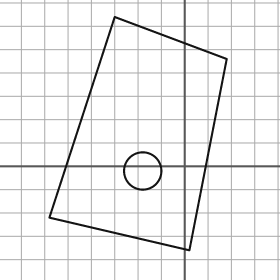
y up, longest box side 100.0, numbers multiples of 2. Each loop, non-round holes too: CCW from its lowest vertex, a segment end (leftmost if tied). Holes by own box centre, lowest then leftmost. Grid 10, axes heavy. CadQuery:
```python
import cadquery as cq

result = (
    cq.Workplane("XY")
    .moveTo(2.0, -36.0)
    .lineTo(18.0, 46.0)
    .lineTo(-30.0, 64.0)
    .lineTo(-58.0, -22.0)
    .close()
    .moveTo(-18.0, -2.0)
    .circle(8.0)
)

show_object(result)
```